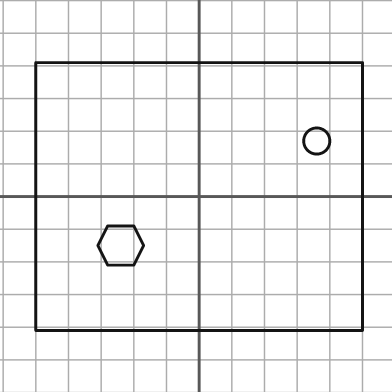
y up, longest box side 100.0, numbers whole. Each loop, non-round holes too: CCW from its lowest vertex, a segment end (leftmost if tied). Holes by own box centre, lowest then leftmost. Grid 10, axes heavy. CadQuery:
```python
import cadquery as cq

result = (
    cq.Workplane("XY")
    .moveTo(-50.0, -41.0)
    .lineTo(50.0, -41.0)
    .lineTo(50.0, 41.0)
    .lineTo(-50.0, 41.0)
    .close()
    .moveTo(-28.0, -21.0)
    .lineTo(-20.0, -21.0)
    .lineTo(-17.0, -15.0)
    .lineTo(-20.0, -9.0)
    .lineTo(-28.0, -9.0)
    .lineTo(-31.0, -15.0)
    .close()
    .moveTo(36.0, 17.0)
    .circle(4.0)
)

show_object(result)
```